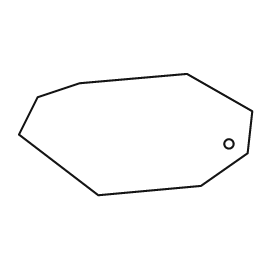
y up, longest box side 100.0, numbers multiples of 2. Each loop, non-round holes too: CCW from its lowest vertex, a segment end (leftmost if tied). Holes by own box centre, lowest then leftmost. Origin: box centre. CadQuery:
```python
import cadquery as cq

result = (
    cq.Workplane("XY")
    .moveTo(-16.0, -26.0)
    .lineTo(28.0, -22.0)
    .lineTo(48.0, -8.0)
    .lineTo(50.0, 10.0)
    .lineTo(22.0, 26.0)
    .lineTo(-24.0, 22.0)
    .lineTo(-42.0, 16.0)
    .lineTo(-50.0, 0.0)
    .close()
    .moveTo(40.0, -4.0)
    .circle(2.0)
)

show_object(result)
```